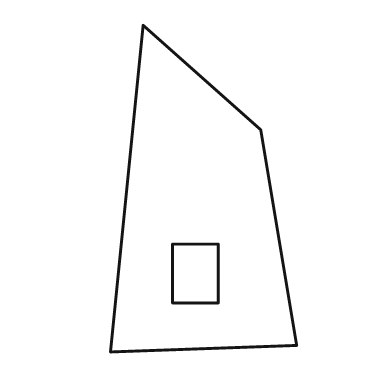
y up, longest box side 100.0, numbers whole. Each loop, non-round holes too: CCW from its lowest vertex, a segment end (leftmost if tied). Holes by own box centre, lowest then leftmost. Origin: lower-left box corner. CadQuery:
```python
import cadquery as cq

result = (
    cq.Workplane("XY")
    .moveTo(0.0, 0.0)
    .lineTo(57.0, 2.0)
    .lineTo(46.0, 68.0)
    .lineTo(10.0, 100.0)
    .close()
    .moveTo(19.0, 15.0)
    .lineTo(33.0, 15.0)
    .lineTo(33.0, 33.0)
    .lineTo(19.0, 33.0)
    .close()
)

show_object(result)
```